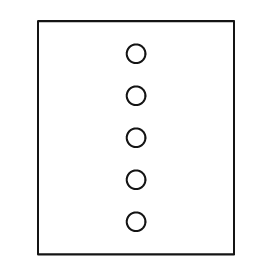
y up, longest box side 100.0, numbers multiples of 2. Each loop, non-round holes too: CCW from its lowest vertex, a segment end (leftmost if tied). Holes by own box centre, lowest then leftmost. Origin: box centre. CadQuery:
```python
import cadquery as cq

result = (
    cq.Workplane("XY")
    .moveTo(-42.0, -50.0)
    .lineTo(42.0, -50.0)
    .lineTo(42.0, 50.0)
    .lineTo(-42.0, 50.0)
    .close()
    .moveTo(0.0, -36.0)
    .circle(4.0)
    .moveTo(0.0, -18.0)
    .circle(4.0)
    .moveTo(0.0, 0.0)
    .circle(4.0)
    .moveTo(0.0, 18.0)
    .circle(4.0)
    .moveTo(0.0, 36.0)
    .circle(4.0)
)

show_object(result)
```